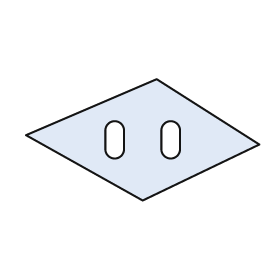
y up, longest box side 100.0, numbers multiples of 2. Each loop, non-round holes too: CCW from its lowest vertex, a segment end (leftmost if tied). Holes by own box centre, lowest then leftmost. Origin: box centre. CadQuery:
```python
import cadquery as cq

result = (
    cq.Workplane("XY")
    .moveTo(0.0, -26.0)
    .lineTo(50.0, -2.0)
    .lineTo(6.0, 26.0)
    .lineTo(-50.0, 2.0)
    .close()
    .moveTo(-16.0, -4.0)
    .threePointArc((-12.0, -8.0), (-8.0, -4.0))
    .lineTo(-8.0, 4.0)
    .threePointArc((-12.0, 8.0), (-16.0, 4.0))
    .close()
    .moveTo(8.0, -4.0)
    .threePointArc((12.0, -8.0), (16.0, -4.0))
    .lineTo(16.0, 4.0)
    .threePointArc((12.0, 8.0), (8.0, 4.0))
    .close()
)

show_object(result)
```